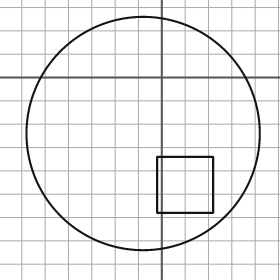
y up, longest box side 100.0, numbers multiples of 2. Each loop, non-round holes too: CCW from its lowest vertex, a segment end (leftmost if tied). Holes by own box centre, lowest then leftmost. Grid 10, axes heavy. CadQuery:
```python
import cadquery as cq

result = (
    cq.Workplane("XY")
    .moveTo(-8.0, -24.0)
    .circle(50.0)
    .moveTo(-2.0, -58.0)
    .lineTo(22.0, -58.0)
    .lineTo(22.0, -34.0)
    .lineTo(-2.0, -34.0)
    .close()
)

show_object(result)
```